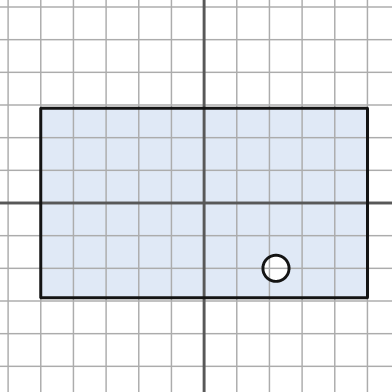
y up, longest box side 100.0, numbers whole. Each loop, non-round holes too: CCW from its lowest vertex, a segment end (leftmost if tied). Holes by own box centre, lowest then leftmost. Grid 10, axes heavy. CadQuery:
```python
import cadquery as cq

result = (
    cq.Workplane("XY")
    .moveTo(-50.0, -29.0)
    .lineTo(50.0, -29.0)
    .lineTo(50.0, 29.0)
    .lineTo(-50.0, 29.0)
    .close()
    .moveTo(22.0, -20.0)
    .circle(4.0)
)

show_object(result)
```